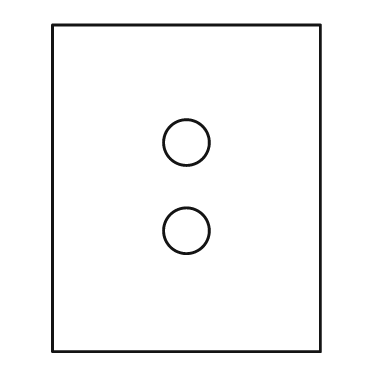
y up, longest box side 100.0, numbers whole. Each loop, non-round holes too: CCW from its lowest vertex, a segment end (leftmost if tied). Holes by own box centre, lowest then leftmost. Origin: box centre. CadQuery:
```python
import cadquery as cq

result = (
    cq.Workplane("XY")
    .moveTo(-41.0, -50.0)
    .lineTo(41.0, -50.0)
    .lineTo(41.0, 50.0)
    .lineTo(-41.0, 50.0)
    .close()
    .moveTo(0.0, -13.0)
    .circle(7.0)
    .moveTo(0.0, 14.0)
    .circle(7.0)
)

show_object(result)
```